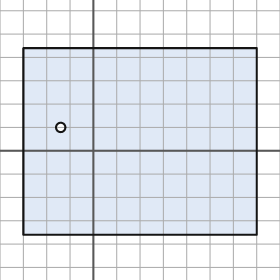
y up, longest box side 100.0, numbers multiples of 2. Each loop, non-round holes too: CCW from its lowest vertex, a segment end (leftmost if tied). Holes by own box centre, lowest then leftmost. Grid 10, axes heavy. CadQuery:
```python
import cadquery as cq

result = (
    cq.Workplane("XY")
    .moveTo(-30.0, -36.0)
    .lineTo(70.0, -36.0)
    .lineTo(70.0, 44.0)
    .lineTo(-30.0, 44.0)
    .close()
    .moveTo(-14.0, 10.0)
    .circle(2.0)
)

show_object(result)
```